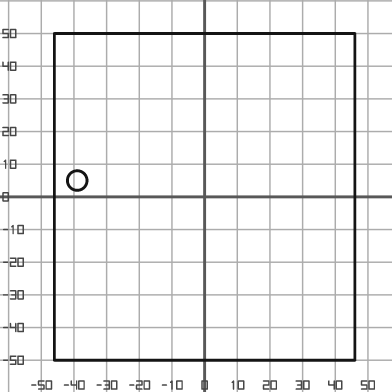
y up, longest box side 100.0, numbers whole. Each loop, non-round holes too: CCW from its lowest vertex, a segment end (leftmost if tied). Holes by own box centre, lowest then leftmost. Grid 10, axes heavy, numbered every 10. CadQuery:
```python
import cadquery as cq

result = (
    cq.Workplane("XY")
    .moveTo(-46.0, -50.0)
    .lineTo(46.0, -50.0)
    .lineTo(46.0, 50.0)
    .lineTo(-46.0, 50.0)
    .close()
    .moveTo(-39.0, 5.0)
    .circle(3.0)
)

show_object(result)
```